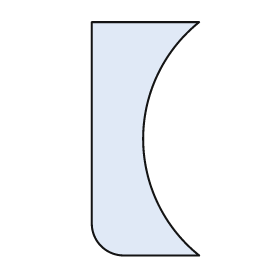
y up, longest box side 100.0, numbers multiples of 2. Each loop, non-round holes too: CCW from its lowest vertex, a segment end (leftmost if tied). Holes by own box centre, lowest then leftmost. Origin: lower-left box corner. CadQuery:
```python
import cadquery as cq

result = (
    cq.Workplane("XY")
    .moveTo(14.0, 0.0)
    .lineTo(46.0, 0.0)
    .threePointArc((22.0, 50.0), (46.0, 100.0))
    .lineTo(0.0, 100.0)
    .lineTo(0.0, 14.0)
    .threePointArc((4.0, 4.0), (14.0, 0.0))
    .close()
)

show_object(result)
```